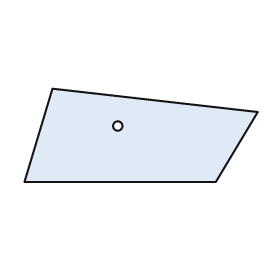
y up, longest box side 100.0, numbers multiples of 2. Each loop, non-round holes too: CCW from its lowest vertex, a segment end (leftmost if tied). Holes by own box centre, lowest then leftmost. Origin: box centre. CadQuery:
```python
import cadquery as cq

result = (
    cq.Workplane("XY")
    .moveTo(-50.0, -20.0)
    .lineTo(32.0, -20.0)
    .lineTo(50.0, 10.0)
    .lineTo(-38.0, 20.0)
    .close()
    .moveTo(-10.0, 4.0)
    .circle(2.0)
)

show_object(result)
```